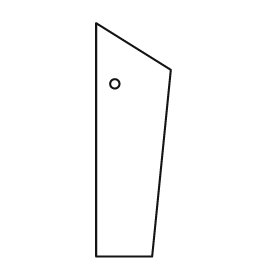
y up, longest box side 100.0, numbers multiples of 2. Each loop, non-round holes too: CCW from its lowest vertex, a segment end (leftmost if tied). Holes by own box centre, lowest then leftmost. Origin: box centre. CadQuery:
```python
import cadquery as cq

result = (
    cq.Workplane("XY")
    .moveTo(-16.0, -50.0)
    .lineTo(8.0, -50.0)
    .lineTo(16.0, 30.0)
    .lineTo(-16.0, 50.0)
    .close()
    .moveTo(-8.0, 24.0)
    .circle(2.0)
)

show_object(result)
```